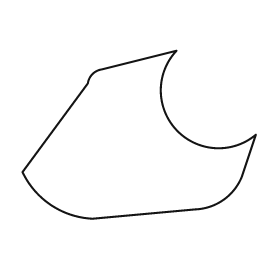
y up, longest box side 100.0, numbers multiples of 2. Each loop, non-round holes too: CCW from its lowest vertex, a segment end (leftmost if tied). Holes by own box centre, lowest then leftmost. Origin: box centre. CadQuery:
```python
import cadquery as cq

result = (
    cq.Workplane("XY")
    .moveTo(-20.0, -36.0)
    .lineTo(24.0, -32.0)
    .threePointArc((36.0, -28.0), (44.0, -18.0))
    .lineTo(50.0, 0.0)
    .threePointArc((16.0, 2.0), (16.0, 36.0))
    .lineTo(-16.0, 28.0)
    .threePointArc((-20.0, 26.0), (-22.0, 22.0))
    .lineTo(-50.0, -16.0)
    .threePointArc((-38.0, -30.0), (-20.0, -36.0))
    .close()
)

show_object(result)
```